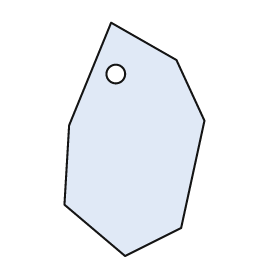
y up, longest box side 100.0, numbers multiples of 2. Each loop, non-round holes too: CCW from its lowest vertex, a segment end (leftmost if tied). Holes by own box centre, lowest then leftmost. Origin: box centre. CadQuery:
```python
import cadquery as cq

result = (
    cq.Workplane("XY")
    .moveTo(-4.0, -50.0)
    .lineTo(20.0, -38.0)
    .lineTo(30.0, 8.0)
    .lineTo(18.0, 34.0)
    .lineTo(-10.0, 50.0)
    .lineTo(-28.0, 6.0)
    .lineTo(-30.0, -28.0)
    .close()
    .moveTo(-8.0, 28.0)
    .circle(4.0)
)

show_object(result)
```